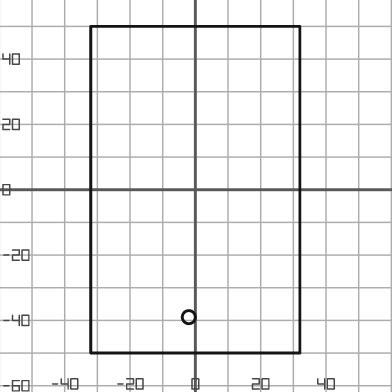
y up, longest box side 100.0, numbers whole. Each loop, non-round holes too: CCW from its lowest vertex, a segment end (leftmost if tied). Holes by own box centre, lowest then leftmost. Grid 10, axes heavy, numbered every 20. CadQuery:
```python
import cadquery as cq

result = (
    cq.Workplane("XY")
    .moveTo(-32.0, -50.0)
    .lineTo(32.0, -50.0)
    .lineTo(32.0, 50.0)
    .lineTo(-32.0, 50.0)
    .close()
    .moveTo(-2.0, -39.0)
    .circle(2.0)
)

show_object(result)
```